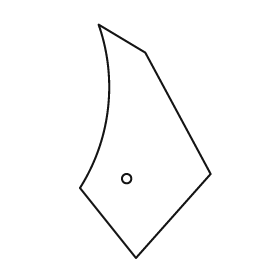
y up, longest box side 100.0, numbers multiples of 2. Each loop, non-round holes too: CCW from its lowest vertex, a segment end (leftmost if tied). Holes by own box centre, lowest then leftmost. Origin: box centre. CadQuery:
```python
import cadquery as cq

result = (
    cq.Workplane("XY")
    .moveTo(-4.0, -50.0)
    .lineTo(28.0, -14.0)
    .lineTo(0.0, 38.0)
    .lineTo(-20.0, 50.0)
    .threePointArc((-16.0, 14.0), (-28.0, -20.0))
    .close()
    .moveTo(-8.0, -16.0)
    .circle(2.0)
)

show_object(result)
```